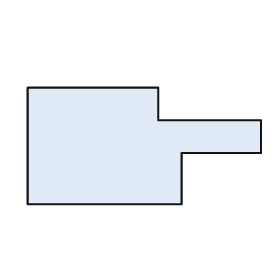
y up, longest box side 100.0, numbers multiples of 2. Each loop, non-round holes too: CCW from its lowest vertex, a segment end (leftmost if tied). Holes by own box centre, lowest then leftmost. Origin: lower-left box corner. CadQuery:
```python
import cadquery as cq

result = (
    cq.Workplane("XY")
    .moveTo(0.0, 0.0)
    .lineTo(66.0, 0.0)
    .lineTo(66.0, 22.0)
    .lineTo(100.0, 22.0)
    .lineTo(100.0, 36.0)
    .lineTo(56.0, 36.0)
    .lineTo(56.0, 50.0)
    .lineTo(0.0, 50.0)
    .close()
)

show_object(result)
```